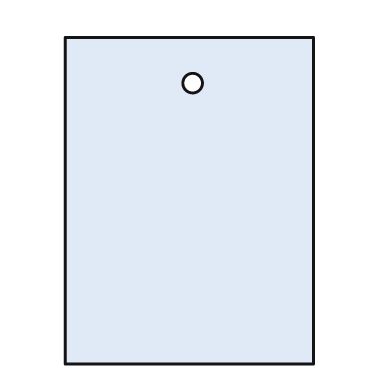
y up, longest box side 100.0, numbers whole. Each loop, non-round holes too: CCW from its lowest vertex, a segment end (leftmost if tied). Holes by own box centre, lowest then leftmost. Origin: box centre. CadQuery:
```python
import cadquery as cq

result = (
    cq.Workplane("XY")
    .moveTo(-38.0, -50.0)
    .lineTo(38.0, -50.0)
    .lineTo(38.0, 50.0)
    .lineTo(-38.0, 50.0)
    .close()
    .moveTo(1.0, 36.0)
    .circle(3.0)
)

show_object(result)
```